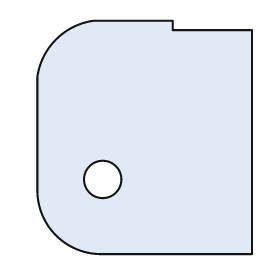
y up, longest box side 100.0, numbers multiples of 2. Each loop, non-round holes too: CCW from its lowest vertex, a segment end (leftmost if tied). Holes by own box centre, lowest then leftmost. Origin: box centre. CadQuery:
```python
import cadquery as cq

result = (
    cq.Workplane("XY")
    .moveTo(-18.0, -50.0)
    .lineTo(46.0, -50.0)
    .lineTo(46.0, 46.0)
    .lineTo(12.0, 46.0)
    .lineTo(12.0, 50.0)
    .lineTo(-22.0, 50.0)
    .threePointArc((-38.0, 42.0), (-46.0, 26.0))
    .lineTo(-46.0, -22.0)
    .threePointArc((-38.0, -42.0), (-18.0, -50.0))
    .close()
    .moveTo(-18.0, -18.0)
    .circle(8.0)
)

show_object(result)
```